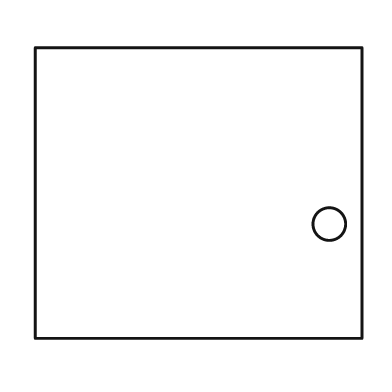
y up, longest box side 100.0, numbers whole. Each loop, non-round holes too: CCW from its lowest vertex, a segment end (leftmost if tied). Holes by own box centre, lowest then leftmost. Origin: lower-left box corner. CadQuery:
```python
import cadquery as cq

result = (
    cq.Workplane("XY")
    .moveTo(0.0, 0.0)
    .lineTo(100.0, 0.0)
    .lineTo(100.0, 89.0)
    .lineTo(0.0, 89.0)
    .close()
    .moveTo(90.0, 35.0)
    .circle(5.0)
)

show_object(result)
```